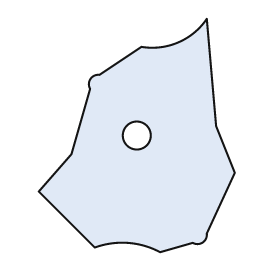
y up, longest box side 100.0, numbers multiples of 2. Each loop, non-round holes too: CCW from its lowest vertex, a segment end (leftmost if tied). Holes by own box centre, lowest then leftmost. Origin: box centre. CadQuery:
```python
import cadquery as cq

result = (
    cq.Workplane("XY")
    .moveTo(10.0, -50.0)
    .lineTo(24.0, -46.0)
    .threePointArc((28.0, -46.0), (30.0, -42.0))
    .lineTo(42.0, -16.0)
    .lineTo(34.0, 4.0)
    .lineTo(30.0, 50.0)
    .threePointArc((18.0, 40.0), (2.0, 38.0))
    .lineTo(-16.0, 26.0)
    .threePointArc((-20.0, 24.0), (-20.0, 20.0))
    .lineTo(-28.0, -8.0)
    .lineTo(-42.0, -24.0)
    .lineTo(-18.0, -48.0)
    .threePointArc((-4.0, -46.0), (10.0, -50.0))
    .close()
    .moveTo(0.0, 0.0)
    .circle(6.0)
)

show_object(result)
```